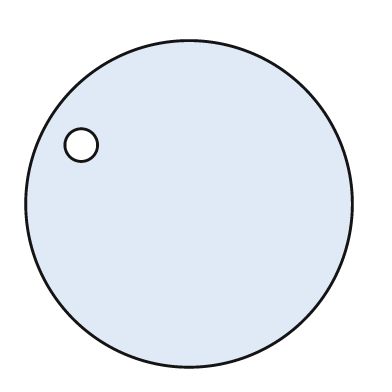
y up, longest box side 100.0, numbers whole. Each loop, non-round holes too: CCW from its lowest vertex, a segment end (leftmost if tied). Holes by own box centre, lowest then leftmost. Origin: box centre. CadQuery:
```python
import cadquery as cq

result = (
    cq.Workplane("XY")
    .moveTo(0.0, 0.0)
    .circle(50.0)
    .moveTo(-33.0, 18.0)
    .circle(5.0)
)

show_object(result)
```